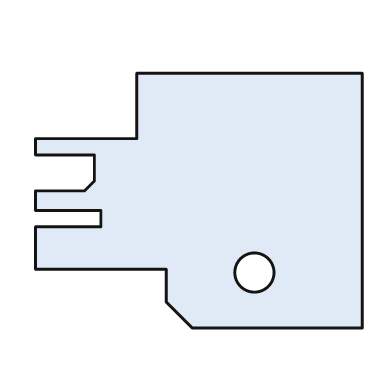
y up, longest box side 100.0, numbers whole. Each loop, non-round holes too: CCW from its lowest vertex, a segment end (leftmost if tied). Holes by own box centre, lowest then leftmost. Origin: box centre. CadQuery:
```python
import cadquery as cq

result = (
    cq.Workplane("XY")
    .moveTo(-2.0, -39.0)
    .lineTo(50.0, -39.0)
    .lineTo(50.0, 39.0)
    .lineTo(-19.0, 39.0)
    .lineTo(-19.0, 19.0)
    .lineTo(-50.0, 19.0)
    .lineTo(-50.0, 14.0)
    .lineTo(-32.0, 14.0)
    .lineTo(-32.0, 6.0)
    .lineTo(-35.0, 3.0)
    .lineTo(-50.0, 3.0)
    .lineTo(-50.0, -3.0)
    .lineTo(-30.0, -3.0)
    .lineTo(-30.0, -8.0)
    .lineTo(-50.0, -8.0)
    .lineTo(-50.0, -21.0)
    .lineTo(-10.0, -21.0)
    .lineTo(-10.0, -31.0)
    .close()
    .moveTo(17.0, -22.0)
    .circle(6.0)
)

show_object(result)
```